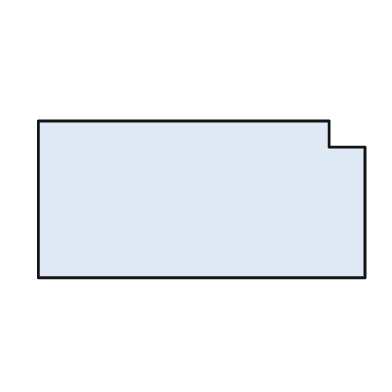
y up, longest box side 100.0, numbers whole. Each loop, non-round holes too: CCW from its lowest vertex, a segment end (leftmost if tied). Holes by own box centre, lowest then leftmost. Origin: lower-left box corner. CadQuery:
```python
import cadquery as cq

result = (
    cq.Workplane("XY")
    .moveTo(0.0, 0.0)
    .lineTo(100.0, 0.0)
    .lineTo(100.0, 40.0)
    .lineTo(89.0, 40.0)
    .lineTo(89.0, 48.0)
    .lineTo(0.0, 48.0)
    .close()
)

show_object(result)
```